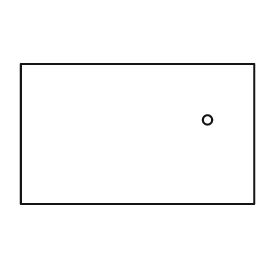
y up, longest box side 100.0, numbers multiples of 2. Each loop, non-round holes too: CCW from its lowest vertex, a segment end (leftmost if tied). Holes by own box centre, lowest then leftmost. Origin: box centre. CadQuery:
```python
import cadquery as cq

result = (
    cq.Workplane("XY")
    .moveTo(-50.0, -30.0)
    .lineTo(50.0, -30.0)
    .lineTo(50.0, 30.0)
    .lineTo(-50.0, 30.0)
    .close()
    .moveTo(30.0, 6.0)
    .circle(2.0)
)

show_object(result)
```